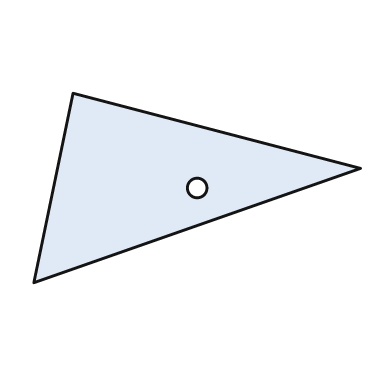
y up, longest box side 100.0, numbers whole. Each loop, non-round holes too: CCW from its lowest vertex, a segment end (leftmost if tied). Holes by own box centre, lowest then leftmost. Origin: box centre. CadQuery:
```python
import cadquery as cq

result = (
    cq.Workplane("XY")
    .moveTo(-50.0, -29.0)
    .lineTo(50.0, 6.0)
    .lineTo(-38.0, 29.0)
    .close()
    .moveTo(0.0, 0.0)
    .circle(3.0)
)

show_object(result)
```